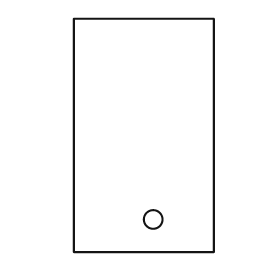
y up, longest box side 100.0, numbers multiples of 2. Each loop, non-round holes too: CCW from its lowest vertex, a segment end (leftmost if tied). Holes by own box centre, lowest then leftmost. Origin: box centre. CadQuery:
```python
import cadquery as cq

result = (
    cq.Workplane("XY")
    .moveTo(-30.0, -50.0)
    .lineTo(30.0, -50.0)
    .lineTo(30.0, 50.0)
    .lineTo(-30.0, 50.0)
    .close()
    .moveTo(4.0, -36.0)
    .circle(4.0)
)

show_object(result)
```